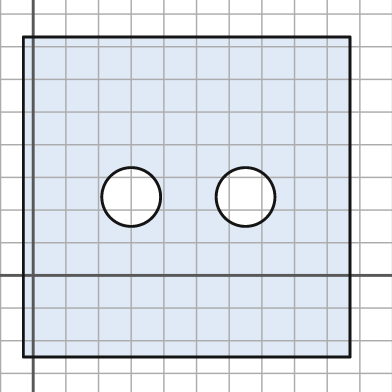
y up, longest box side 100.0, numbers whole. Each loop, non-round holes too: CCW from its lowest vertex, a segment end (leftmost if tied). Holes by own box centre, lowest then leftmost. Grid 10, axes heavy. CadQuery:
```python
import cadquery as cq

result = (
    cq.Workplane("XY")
    .moveTo(-3.0, -25.0)
    .lineTo(97.0, -25.0)
    .lineTo(97.0, 73.0)
    .lineTo(-3.0, 73.0)
    .close()
    .moveTo(30.0, 24.0)
    .circle(9.0)
    .moveTo(65.0, 24.0)
    .circle(9.0)
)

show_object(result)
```